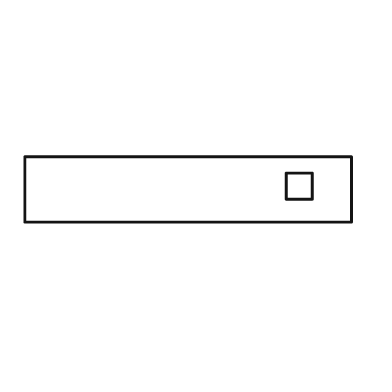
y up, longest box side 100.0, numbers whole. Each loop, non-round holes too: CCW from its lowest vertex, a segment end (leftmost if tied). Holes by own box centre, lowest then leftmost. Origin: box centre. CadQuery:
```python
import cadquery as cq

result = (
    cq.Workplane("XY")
    .moveTo(-50.0, -10.0)
    .lineTo(50.0, -10.0)
    .lineTo(50.0, 10.0)
    .lineTo(-50.0, 10.0)
    .close()
    .moveTo(30.0, -3.0)
    .lineTo(38.0, -3.0)
    .lineTo(38.0, 5.0)
    .lineTo(30.0, 5.0)
    .close()
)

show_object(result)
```